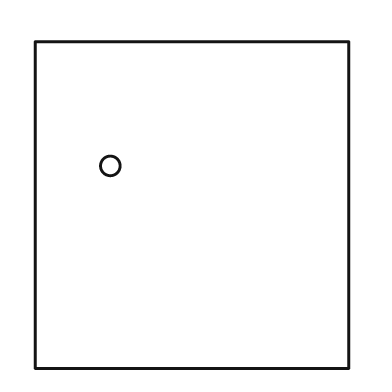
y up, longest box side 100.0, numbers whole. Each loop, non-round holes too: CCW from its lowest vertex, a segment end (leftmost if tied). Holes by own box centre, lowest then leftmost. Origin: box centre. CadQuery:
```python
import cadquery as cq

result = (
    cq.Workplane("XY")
    .moveTo(-48.0, -50.0)
    .lineTo(48.0, -50.0)
    .lineTo(48.0, 50.0)
    .lineTo(-48.0, 50.0)
    .close()
    .moveTo(-25.0, 12.0)
    .circle(3.0)
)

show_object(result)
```